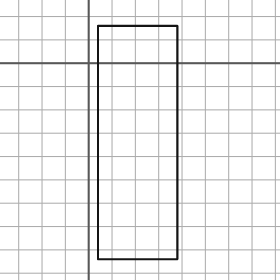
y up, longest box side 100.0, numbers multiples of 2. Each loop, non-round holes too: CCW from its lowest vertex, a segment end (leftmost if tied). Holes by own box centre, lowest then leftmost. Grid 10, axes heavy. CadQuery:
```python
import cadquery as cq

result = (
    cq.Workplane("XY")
    .moveTo(4.0, -84.0)
    .lineTo(38.0, -84.0)
    .lineTo(38.0, 16.0)
    .lineTo(4.0, 16.0)
    .close()
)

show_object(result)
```